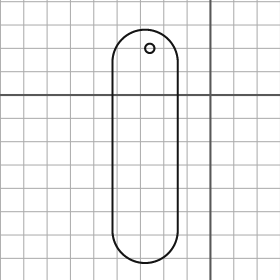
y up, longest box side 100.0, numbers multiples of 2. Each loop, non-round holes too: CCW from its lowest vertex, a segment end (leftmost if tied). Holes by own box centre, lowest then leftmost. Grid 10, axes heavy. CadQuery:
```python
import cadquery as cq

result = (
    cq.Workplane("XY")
    .moveTo(-42.0, -58.0)
    .threePointArc((-28.0, -72.0), (-14.0, -58.0))
    .lineTo(-14.0, 14.0)
    .threePointArc((-28.0, 28.0), (-42.0, 14.0))
    .close()
    .moveTo(-26.0, 20.0)
    .circle(2.0)
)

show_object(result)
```